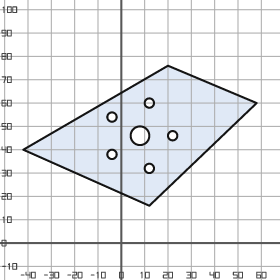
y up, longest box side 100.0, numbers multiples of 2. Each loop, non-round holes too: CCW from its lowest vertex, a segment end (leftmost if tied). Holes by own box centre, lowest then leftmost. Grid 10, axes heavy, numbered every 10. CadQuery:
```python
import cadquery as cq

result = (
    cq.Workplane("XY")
    .moveTo(12.0, 16.0)
    .lineTo(58.0, 60.0)
    .lineTo(20.0, 76.0)
    .lineTo(-42.0, 40.0)
    .close()
    .moveTo(12.0, 32.0)
    .circle(2.0)
    .moveTo(-4.0, 38.0)
    .circle(2.0)
    .moveTo(8.0, 46.0)
    .circle(4.0)
    .moveTo(22.0, 46.0)
    .circle(2.0)
    .moveTo(-4.0, 54.0)
    .circle(2.0)
    .moveTo(12.0, 60.0)
    .circle(2.0)
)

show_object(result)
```